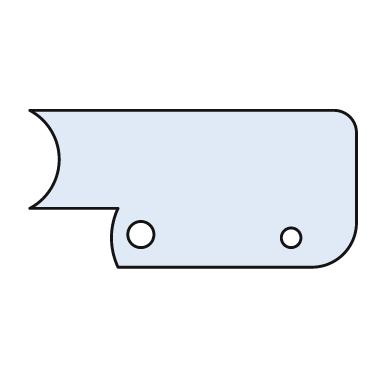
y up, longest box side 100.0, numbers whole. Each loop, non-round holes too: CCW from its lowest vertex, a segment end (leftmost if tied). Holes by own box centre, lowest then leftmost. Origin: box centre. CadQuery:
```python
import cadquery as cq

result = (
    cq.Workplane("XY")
    .moveTo(-23.0, -24.0)
    .lineTo(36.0, -24.0)
    .threePointArc((46.0, -20.0), (50.0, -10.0))
    .lineTo(50.0, 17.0)
    .threePointArc((48.0, 22.0), (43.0, 24.0))
    .lineTo(-50.0, 24.0)
    .threePointArc((-41.0, 9.0), (-50.0, -6.0))
    .lineTo(-23.0, -6.0)
    .threePointArc((-25.0, -15.0), (-23.0, -24.0))
    .close()
    .moveTo(30.0, -15.0)
    .circle(3.0)
    .moveTo(-16.0, -14.0)
    .circle(4.0)
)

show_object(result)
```